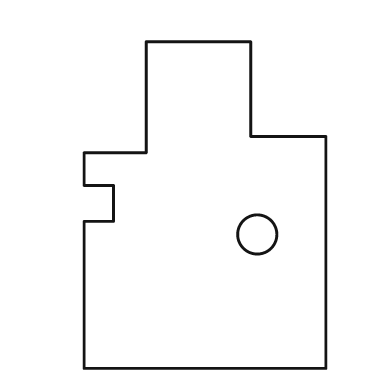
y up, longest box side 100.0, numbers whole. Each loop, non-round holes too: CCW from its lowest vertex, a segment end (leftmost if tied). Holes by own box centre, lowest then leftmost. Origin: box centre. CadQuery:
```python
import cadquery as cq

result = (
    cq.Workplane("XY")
    .moveTo(-37.0, -50.0)
    .lineTo(37.0, -50.0)
    .lineTo(37.0, 21.0)
    .lineTo(14.0, 21.0)
    .lineTo(14.0, 50.0)
    .lineTo(-18.0, 50.0)
    .lineTo(-18.0, 16.0)
    .lineTo(-37.0, 16.0)
    .lineTo(-37.0, 6.0)
    .lineTo(-28.0, 6.0)
    .lineTo(-28.0, -5.0)
    .lineTo(-37.0, -5.0)
    .close()
    .moveTo(16.0, -9.0)
    .circle(6.0)
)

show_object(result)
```